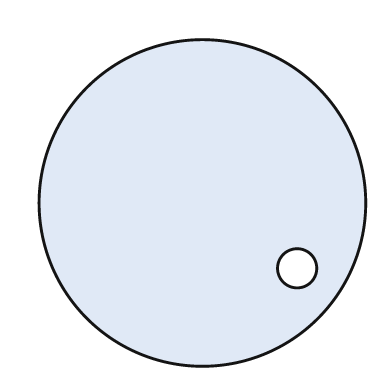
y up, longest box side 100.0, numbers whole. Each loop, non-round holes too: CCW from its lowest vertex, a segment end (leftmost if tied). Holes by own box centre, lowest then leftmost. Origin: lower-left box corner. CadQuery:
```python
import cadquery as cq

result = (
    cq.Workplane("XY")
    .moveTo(50.0, 50.0)
    .circle(50.0)
    .moveTo(79.0, 30.0)
    .circle(6.0)
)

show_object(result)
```